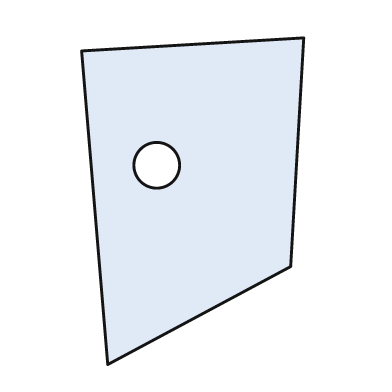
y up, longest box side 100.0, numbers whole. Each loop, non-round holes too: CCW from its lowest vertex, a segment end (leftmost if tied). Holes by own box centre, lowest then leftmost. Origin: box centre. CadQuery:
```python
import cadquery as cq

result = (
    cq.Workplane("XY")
    .moveTo(-26.0, -50.0)
    .lineTo(30.0, -20.0)
    .lineTo(34.0, 50.0)
    .lineTo(-34.0, 46.0)
    .close()
    .moveTo(-11.0, 11.0)
    .circle(7.0)
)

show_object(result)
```